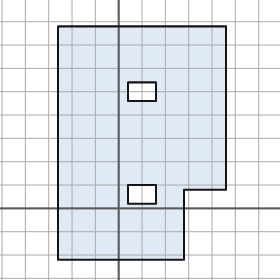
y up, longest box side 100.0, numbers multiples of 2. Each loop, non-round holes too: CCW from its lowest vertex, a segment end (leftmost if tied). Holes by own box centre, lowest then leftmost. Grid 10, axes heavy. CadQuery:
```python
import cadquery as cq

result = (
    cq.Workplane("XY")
    .moveTo(-26.0, -22.0)
    .lineTo(28.0, -22.0)
    .lineTo(28.0, 8.0)
    .lineTo(46.0, 8.0)
    .lineTo(46.0, 78.0)
    .lineTo(-26.0, 78.0)
    .close()
    .moveTo(4.0, 2.0)
    .lineTo(16.0, 2.0)
    .lineTo(16.0, 10.0)
    .lineTo(4.0, 10.0)
    .close()
    .moveTo(4.0, 46.0)
    .lineTo(16.0, 46.0)
    .lineTo(16.0, 54.0)
    .lineTo(4.0, 54.0)
    .close()
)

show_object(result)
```